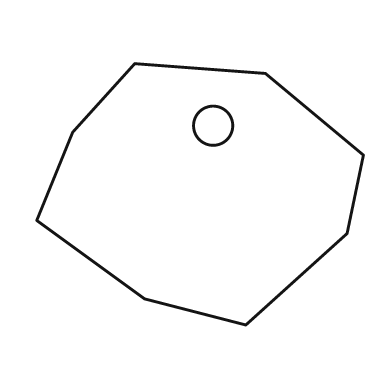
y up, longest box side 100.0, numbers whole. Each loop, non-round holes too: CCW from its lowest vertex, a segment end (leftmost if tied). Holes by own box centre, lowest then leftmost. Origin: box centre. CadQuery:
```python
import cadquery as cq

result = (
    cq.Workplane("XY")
    .moveTo(14.0, -40.0)
    .lineTo(45.0, -12.0)
    .lineTo(50.0, 12.0)
    .lineTo(20.0, 37.0)
    .lineTo(-20.0, 40.0)
    .lineTo(-39.0, 19.0)
    .lineTo(-50.0, -8.0)
    .lineTo(-17.0, -32.0)
    .close()
    .moveTo(4.0, 21.0)
    .circle(6.0)
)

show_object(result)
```